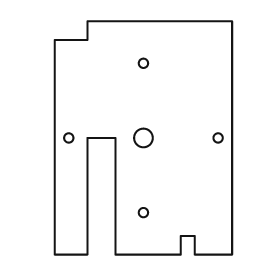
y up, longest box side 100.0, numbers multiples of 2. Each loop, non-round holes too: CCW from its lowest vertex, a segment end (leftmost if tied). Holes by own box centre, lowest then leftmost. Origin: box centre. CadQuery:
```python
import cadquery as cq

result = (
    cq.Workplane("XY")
    .moveTo(-38.0, -50.0)
    .lineTo(-24.0, -50.0)
    .lineTo(-24.0, 0.0)
    .lineTo(-12.0, 0.0)
    .lineTo(-12.0, -50.0)
    .lineTo(16.0, -50.0)
    .lineTo(16.0, -42.0)
    .lineTo(22.0, -42.0)
    .lineTo(22.0, -50.0)
    .lineTo(38.0, -50.0)
    .lineTo(38.0, 50.0)
    .lineTo(-24.0, 50.0)
    .lineTo(-24.0, 42.0)
    .lineTo(-38.0, 42.0)
    .close()
    .moveTo(0.0, -32.0)
    .circle(2.0)
    .moveTo(-32.0, 0.0)
    .circle(2.0)
    .moveTo(0.0, 0.0)
    .circle(4.0)
    .moveTo(32.0, 0.0)
    .circle(2.0)
    .moveTo(0.0, 32.0)
    .circle(2.0)
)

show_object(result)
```